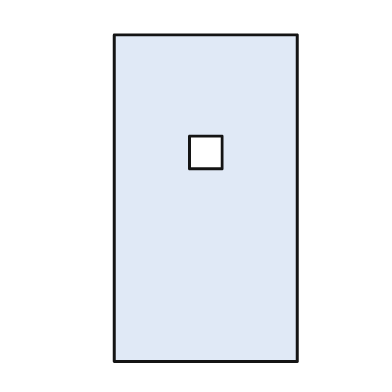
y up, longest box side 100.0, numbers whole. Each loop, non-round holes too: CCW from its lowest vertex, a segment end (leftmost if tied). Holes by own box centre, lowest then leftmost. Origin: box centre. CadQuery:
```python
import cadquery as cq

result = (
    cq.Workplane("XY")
    .moveTo(-28.0, -50.0)
    .lineTo(28.0, -50.0)
    .lineTo(28.0, 50.0)
    .lineTo(-28.0, 50.0)
    .close()
    .moveTo(-5.0, 9.0)
    .lineTo(5.0, 9.0)
    .lineTo(5.0, 19.0)
    .lineTo(-5.0, 19.0)
    .close()
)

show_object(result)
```